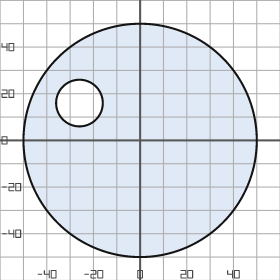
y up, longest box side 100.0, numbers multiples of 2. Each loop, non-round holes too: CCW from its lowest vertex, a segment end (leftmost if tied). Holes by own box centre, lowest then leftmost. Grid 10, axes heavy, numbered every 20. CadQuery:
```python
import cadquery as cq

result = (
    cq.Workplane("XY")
    .moveTo(0.0, 0.0)
    .circle(50.0)
    .moveTo(-26.0, 16.0)
    .circle(10.0)
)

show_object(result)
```